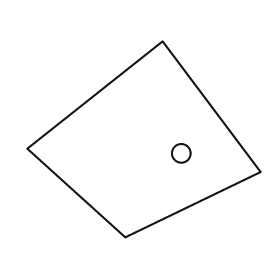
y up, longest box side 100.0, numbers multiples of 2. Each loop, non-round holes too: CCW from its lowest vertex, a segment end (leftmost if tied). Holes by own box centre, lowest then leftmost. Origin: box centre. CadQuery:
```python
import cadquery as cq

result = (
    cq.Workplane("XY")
    .moveTo(-8.0, -42.0)
    .lineTo(50.0, -14.0)
    .lineTo(8.0, 42.0)
    .lineTo(-50.0, -4.0)
    .close()
    .moveTo(16.0, -6.0)
    .circle(4.0)
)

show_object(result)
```